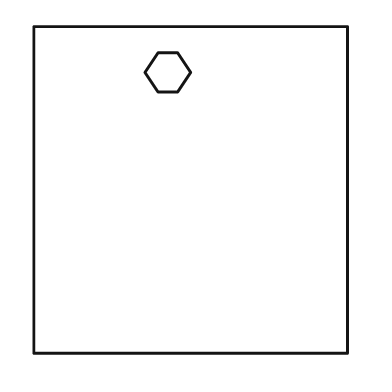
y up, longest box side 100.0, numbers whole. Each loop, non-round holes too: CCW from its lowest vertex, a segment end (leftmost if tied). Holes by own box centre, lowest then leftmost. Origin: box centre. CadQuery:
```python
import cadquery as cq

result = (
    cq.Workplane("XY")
    .moveTo(-48.0, -50.0)
    .lineTo(48.0, -50.0)
    .lineTo(48.0, 50.0)
    .lineTo(-48.0, 50.0)
    .close()
    .moveTo(-10.0, 30.0)
    .lineTo(-4.0, 30.0)
    .lineTo(0.0, 36.0)
    .lineTo(-4.0, 42.0)
    .lineTo(-10.0, 42.0)
    .lineTo(-14.0, 36.0)
    .close()
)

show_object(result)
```